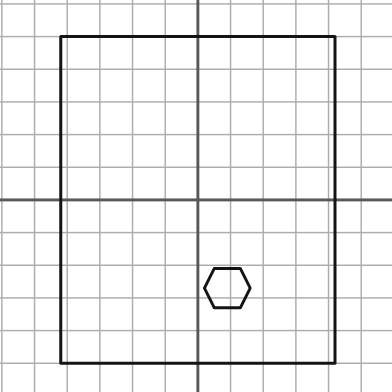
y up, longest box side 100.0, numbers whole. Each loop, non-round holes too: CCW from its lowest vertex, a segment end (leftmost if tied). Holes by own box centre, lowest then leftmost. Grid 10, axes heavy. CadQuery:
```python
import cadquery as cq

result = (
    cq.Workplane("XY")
    .moveTo(-42.0, -50.0)
    .lineTo(42.0, -50.0)
    .lineTo(42.0, 50.0)
    .lineTo(-42.0, 50.0)
    .close()
    .moveTo(5.0, -33.0)
    .lineTo(13.0, -33.0)
    .lineTo(16.0, -27.0)
    .lineTo(13.0, -21.0)
    .lineTo(5.0, -21.0)
    .lineTo(2.0, -27.0)
    .close()
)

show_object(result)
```